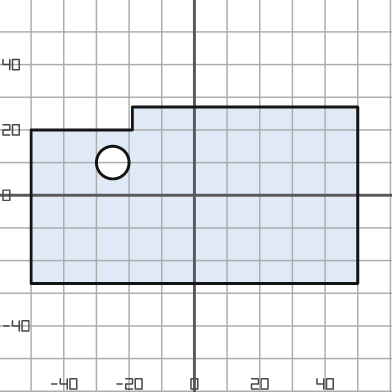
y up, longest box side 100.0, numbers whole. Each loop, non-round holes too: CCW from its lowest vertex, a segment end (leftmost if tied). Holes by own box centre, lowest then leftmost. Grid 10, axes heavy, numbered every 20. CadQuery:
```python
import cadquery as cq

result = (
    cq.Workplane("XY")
    .moveTo(-50.0, -27.0)
    .lineTo(50.0, -27.0)
    .lineTo(50.0, 27.0)
    .lineTo(-19.0, 27.0)
    .lineTo(-19.0, 20.0)
    .lineTo(-50.0, 20.0)
    .close()
    .moveTo(-25.0, 10.0)
    .circle(5.0)
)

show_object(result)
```